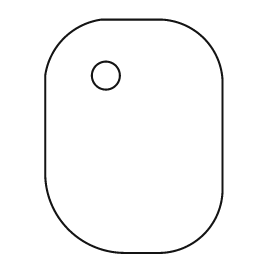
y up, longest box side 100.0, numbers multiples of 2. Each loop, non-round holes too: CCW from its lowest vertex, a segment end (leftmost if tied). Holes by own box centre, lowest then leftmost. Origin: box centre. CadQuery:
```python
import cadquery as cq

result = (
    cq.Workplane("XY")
    .moveTo(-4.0, -50.0)
    .lineTo(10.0, -50.0)
    .threePointArc((30.0, -42.0), (38.0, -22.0))
    .lineTo(38.0, 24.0)
    .threePointArc((30.0, 42.0), (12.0, 50.0))
    .lineTo(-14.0, 50.0)
    .threePointArc((-30.0, 42.0), (-38.0, 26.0))
    .lineTo(-38.0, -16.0)
    .threePointArc((-28.0, -40.0), (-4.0, -50.0))
    .close()
    .moveTo(-12.0, 26.0)
    .circle(6.0)
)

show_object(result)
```